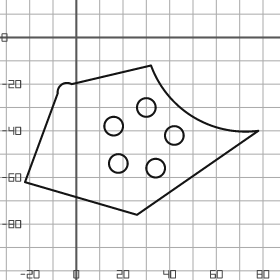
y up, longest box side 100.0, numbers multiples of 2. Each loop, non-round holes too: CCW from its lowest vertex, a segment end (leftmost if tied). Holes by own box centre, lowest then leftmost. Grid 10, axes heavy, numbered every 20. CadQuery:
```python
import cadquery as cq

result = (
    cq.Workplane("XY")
    .moveTo(26.0, -76.0)
    .lineTo(78.0, -40.0)
    .threePointArc((50.0, -34.0), (32.0, -12.0))
    .lineTo(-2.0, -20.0)
    .threePointArc((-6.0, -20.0), (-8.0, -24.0))
    .lineTo(-22.0, -62.0)
    .close()
    .moveTo(34.0, -56.0)
    .circle(4.0)
    .moveTo(18.0, -54.0)
    .circle(4.0)
    .moveTo(42.0, -42.0)
    .circle(4.0)
    .moveTo(16.0, -38.0)
    .circle(4.0)
    .moveTo(30.0, -30.0)
    .circle(4.0)
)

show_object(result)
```